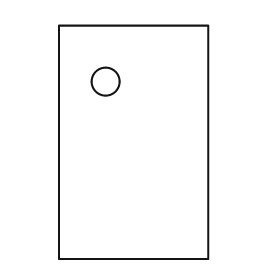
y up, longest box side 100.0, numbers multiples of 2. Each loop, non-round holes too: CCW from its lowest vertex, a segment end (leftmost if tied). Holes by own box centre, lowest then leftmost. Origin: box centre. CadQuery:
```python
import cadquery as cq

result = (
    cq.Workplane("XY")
    .moveTo(-32.0, -50.0)
    .lineTo(32.0, -50.0)
    .lineTo(32.0, 50.0)
    .lineTo(-32.0, 50.0)
    .close()
    .moveTo(-12.0, 26.0)
    .circle(6.0)
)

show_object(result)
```